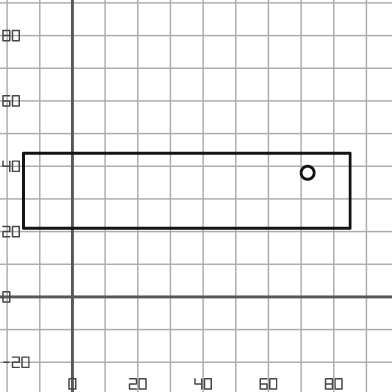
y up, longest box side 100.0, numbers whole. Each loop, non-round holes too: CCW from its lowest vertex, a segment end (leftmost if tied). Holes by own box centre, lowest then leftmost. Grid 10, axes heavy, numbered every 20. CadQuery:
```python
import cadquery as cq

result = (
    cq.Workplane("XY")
    .moveTo(-15.0, 21.0)
    .lineTo(85.0, 21.0)
    .lineTo(85.0, 44.0)
    .lineTo(-15.0, 44.0)
    .close()
    .moveTo(72.0, 38.0)
    .circle(2.0)
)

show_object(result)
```